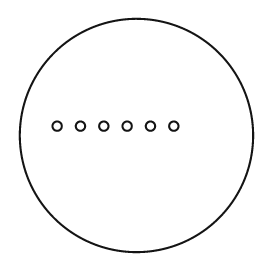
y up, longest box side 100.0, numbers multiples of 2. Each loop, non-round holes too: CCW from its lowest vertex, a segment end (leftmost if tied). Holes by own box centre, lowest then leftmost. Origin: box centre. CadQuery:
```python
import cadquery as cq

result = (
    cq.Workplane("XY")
    .moveTo(0.0, 0.0)
    .circle(50.0)
    .moveTo(-34.0, 4.0)
    .circle(2.0)
    .moveTo(-24.0, 4.0)
    .circle(2.0)
    .moveTo(-14.0, 4.0)
    .circle(2.0)
    .moveTo(-4.0, 4.0)
    .circle(2.0)
    .moveTo(6.0, 4.0)
    .circle(2.0)
    .moveTo(16.0, 4.0)
    .circle(2.0)
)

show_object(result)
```